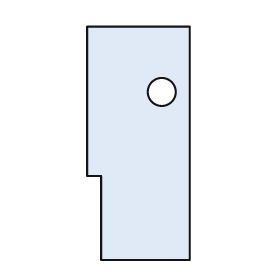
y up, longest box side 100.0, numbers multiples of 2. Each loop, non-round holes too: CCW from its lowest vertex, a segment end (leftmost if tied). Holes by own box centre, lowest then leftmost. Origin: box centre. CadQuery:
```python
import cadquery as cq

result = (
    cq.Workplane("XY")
    .moveTo(-16.0, -50.0)
    .lineTo(22.0, -50.0)
    .lineTo(22.0, 50.0)
    .lineTo(-22.0, 50.0)
    .lineTo(-22.0, -14.0)
    .lineTo(-16.0, -14.0)
    .close()
    .moveTo(10.0, 22.0)
    .circle(6.0)
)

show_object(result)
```